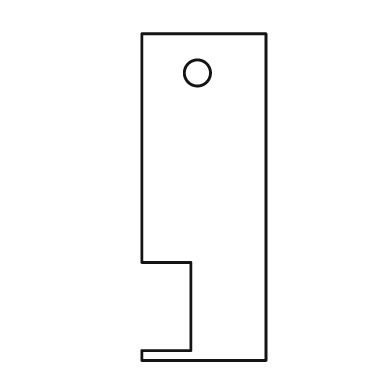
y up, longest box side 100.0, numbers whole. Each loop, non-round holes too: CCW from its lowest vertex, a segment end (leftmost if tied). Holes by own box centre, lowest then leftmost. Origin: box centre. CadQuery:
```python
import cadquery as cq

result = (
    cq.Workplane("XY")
    .moveTo(-19.0, -50.0)
    .lineTo(19.0, -50.0)
    .lineTo(19.0, 50.0)
    .lineTo(-19.0, 50.0)
    .lineTo(-19.0, -20.0)
    .lineTo(-4.0, -20.0)
    .lineTo(-4.0, -47.0)
    .lineTo(-19.0, -47.0)
    .close()
    .moveTo(-2.0, 38.0)
    .circle(4.0)
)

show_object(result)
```